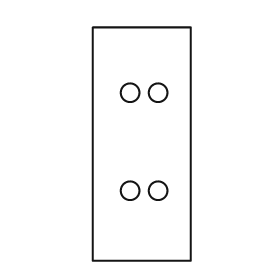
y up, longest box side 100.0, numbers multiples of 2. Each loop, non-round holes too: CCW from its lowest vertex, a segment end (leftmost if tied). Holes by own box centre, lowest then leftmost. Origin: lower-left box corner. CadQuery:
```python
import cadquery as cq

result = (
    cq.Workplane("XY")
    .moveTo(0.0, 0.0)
    .lineTo(42.0, 0.0)
    .lineTo(42.0, 100.0)
    .lineTo(0.0, 100.0)
    .close()
    .moveTo(16.0, 30.0)
    .circle(4.0)
    .moveTo(28.0, 30.0)
    .circle(4.0)
    .moveTo(16.0, 72.0)
    .circle(4.0)
    .moveTo(28.0, 72.0)
    .circle(4.0)
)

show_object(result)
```